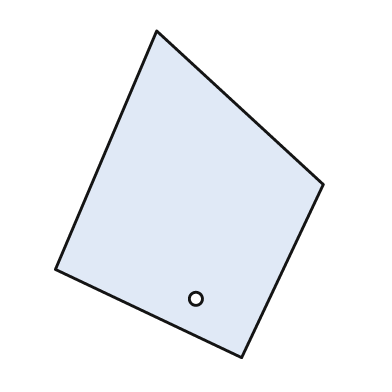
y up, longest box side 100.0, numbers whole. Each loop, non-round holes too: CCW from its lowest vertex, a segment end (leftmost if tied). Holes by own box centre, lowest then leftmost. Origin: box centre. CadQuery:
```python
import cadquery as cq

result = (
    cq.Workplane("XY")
    .moveTo(16.0, -50.0)
    .lineTo(41.0, 3.0)
    .lineTo(-10.0, 50.0)
    .lineTo(-41.0, -23.0)
    .close()
    .moveTo(2.0, -32.0)
    .circle(2.0)
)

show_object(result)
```